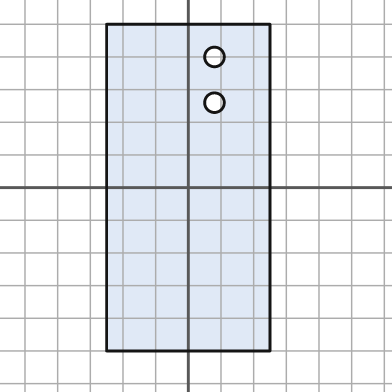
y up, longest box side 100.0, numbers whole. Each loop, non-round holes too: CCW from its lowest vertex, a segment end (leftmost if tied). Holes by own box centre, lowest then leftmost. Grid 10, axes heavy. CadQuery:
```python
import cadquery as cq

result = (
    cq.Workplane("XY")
    .moveTo(-25.0, -50.0)
    .lineTo(25.0, -50.0)
    .lineTo(25.0, 50.0)
    .lineTo(-25.0, 50.0)
    .close()
    .moveTo(8.0, 26.0)
    .circle(3.0)
    .moveTo(8.0, 40.0)
    .circle(3.0)
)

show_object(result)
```